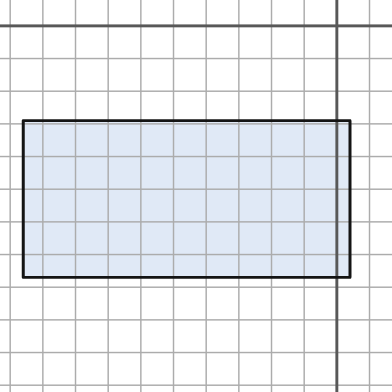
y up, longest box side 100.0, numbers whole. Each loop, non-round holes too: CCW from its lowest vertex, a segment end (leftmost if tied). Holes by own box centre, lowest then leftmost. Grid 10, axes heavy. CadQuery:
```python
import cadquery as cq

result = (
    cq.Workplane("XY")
    .moveTo(-96.0, -77.0)
    .lineTo(4.0, -77.0)
    .lineTo(4.0, -29.0)
    .lineTo(-96.0, -29.0)
    .close()
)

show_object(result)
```